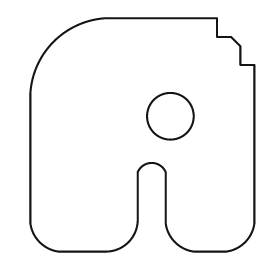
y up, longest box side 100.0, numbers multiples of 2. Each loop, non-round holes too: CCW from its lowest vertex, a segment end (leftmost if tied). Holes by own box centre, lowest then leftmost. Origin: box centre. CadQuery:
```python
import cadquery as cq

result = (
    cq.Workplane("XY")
    .moveTo(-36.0, -50.0)
    .lineTo(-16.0, -50.0)
    .threePointArc((-6.0, -46.0), (-2.0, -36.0))
    .lineTo(-2.0, -16.0)
    .threePointArc((4.0, -12.0), (10.0, -16.0))
    .lineTo(10.0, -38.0)
    .threePointArc((14.0, -46.0), (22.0, -50.0))
    .lineTo(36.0, -50.0)
    .threePointArc((44.0, -46.0), (48.0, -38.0))
    .lineTo(48.0, 30.0)
    .lineTo(42.0, 30.0)
    .lineTo(42.0, 38.0)
    .lineTo(38.0, 42.0)
    .lineTo(32.0, 42.0)
    .lineTo(32.0, 50.0)
    .lineTo(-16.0, 50.0)
    .threePointArc((-38.0, 40.0), (-48.0, 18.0))
    .lineTo(-48.0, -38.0)
    .threePointArc((-44.0, -46.0), (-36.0, -50.0))
    .close()
    .moveTo(12.0, 8.0)
    .circle(10.0)
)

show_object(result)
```